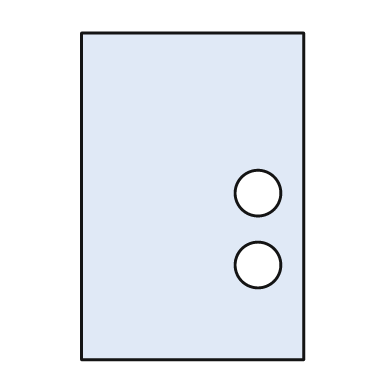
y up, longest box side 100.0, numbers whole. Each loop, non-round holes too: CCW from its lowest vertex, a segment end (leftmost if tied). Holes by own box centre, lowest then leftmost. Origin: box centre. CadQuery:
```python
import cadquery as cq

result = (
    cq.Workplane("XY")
    .moveTo(-34.0, -50.0)
    .lineTo(34.0, -50.0)
    .lineTo(34.0, 50.0)
    .lineTo(-34.0, 50.0)
    .close()
    .moveTo(20.0, -21.0)
    .circle(7.0)
    .moveTo(20.0, 1.0)
    .circle(7.0)
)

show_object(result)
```